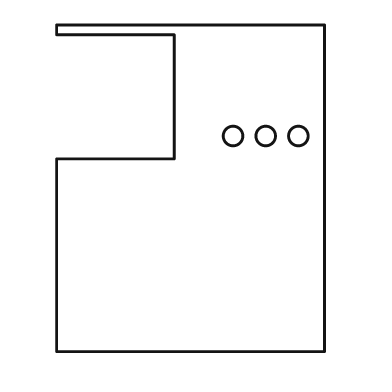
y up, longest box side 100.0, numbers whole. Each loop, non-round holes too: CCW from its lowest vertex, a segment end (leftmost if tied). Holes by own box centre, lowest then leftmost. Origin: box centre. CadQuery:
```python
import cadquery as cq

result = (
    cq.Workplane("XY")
    .moveTo(-41.0, -50.0)
    .lineTo(41.0, -50.0)
    .lineTo(41.0, 50.0)
    .lineTo(-41.0, 50.0)
    .lineTo(-41.0, 47.0)
    .lineTo(-5.0, 47.0)
    .lineTo(-5.0, 9.0)
    .lineTo(-41.0, 9.0)
    .close()
    .moveTo(13.0, 16.0)
    .circle(3.0)
    .moveTo(23.0, 16.0)
    .circle(3.0)
    .moveTo(33.0, 16.0)
    .circle(3.0)
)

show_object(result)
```